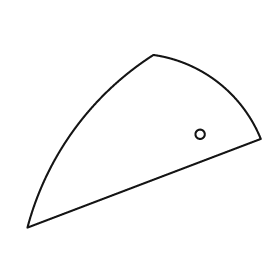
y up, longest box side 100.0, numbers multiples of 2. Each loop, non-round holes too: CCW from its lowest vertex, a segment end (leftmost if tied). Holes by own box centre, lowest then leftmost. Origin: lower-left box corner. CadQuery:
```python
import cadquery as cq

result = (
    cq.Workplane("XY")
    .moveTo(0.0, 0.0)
    .lineTo(100.0, 38.0)
    .threePointArc((82.0, 62.0), (54.0, 74.0))
    .threePointArc((20.0, 42.0), (0.0, 0.0))
    .close()
    .moveTo(74.0, 40.0)
    .circle(2.0)
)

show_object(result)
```